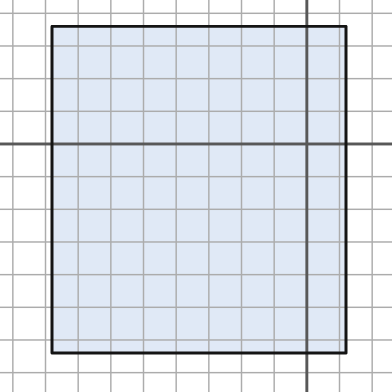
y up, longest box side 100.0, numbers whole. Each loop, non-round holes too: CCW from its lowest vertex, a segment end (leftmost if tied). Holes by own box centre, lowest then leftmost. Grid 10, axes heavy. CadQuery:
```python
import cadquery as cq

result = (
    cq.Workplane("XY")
    .moveTo(-78.0, -64.0)
    .lineTo(12.0, -64.0)
    .lineTo(12.0, 36.0)
    .lineTo(-78.0, 36.0)
    .close()
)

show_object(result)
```